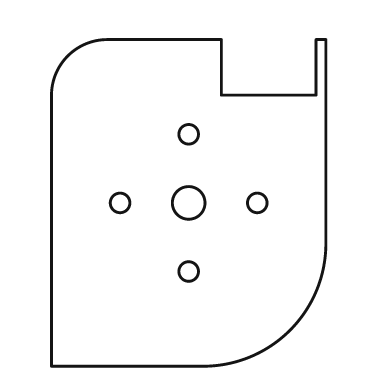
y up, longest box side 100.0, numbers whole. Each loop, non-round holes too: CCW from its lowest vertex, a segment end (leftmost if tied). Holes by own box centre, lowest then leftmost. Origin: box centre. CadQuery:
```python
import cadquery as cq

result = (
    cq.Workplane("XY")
    .moveTo(-42.0, -50.0)
    .lineTo(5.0, -50.0)
    .threePointArc((31.0, -39.0), (42.0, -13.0))
    .lineTo(42.0, 50.0)
    .lineTo(39.0, 50.0)
    .lineTo(39.0, 33.0)
    .lineTo(10.0, 33.0)
    .lineTo(10.0, 50.0)
    .lineTo(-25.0, 50.0)
    .threePointArc((-37.0, 45.0), (-42.0, 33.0))
    .close()
    .moveTo(0.0, -21.0)
    .circle(3.0)
    .moveTo(-21.0, 0.0)
    .circle(3.0)
    .moveTo(0.0, 0.0)
    .circle(5.0)
    .moveTo(21.0, 0.0)
    .circle(3.0)
    .moveTo(0.0, 21.0)
    .circle(3.0)
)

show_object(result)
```